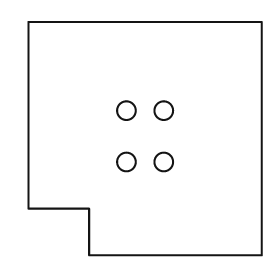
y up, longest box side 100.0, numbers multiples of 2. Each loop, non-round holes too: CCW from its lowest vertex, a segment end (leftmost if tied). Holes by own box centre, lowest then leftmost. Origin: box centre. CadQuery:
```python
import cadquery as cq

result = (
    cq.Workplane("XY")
    .moveTo(-24.0, -50.0)
    .lineTo(50.0, -50.0)
    .lineTo(50.0, 50.0)
    .lineTo(-50.0, 50.0)
    .lineTo(-50.0, -30.0)
    .lineTo(-24.0, -30.0)
    .close()
    .moveTo(-8.0, -10.0)
    .circle(4.0)
    .moveTo(8.0, -10.0)
    .circle(4.0)
    .moveTo(-8.0, 12.0)
    .circle(4.0)
    .moveTo(8.0, 12.0)
    .circle(4.0)
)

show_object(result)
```